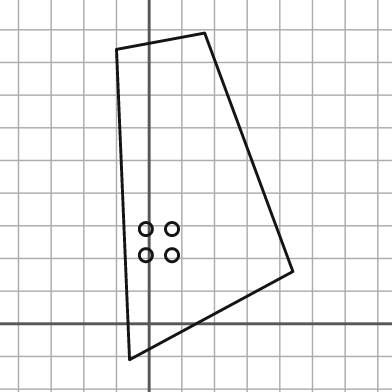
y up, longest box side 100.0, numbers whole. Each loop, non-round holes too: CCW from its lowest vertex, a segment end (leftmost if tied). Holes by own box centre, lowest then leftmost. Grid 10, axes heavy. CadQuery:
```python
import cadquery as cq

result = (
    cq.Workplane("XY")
    .moveTo(-6.0, -11.0)
    .lineTo(44.0, 16.0)
    .lineTo(17.0, 89.0)
    .lineTo(-10.0, 84.0)
    .close()
    .moveTo(-1.0, 21.0)
    .circle(2.0)
    .moveTo(7.0, 21.0)
    .circle(2.0)
    .moveTo(-1.0, 29.0)
    .circle(2.0)
    .moveTo(7.0, 29.0)
    .circle(2.0)
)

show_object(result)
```